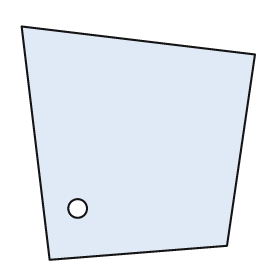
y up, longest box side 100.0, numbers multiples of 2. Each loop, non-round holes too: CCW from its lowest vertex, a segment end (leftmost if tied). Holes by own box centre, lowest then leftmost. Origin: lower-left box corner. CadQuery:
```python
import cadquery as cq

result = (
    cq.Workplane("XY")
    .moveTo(12.0, 0.0)
    .lineTo(88.0, 6.0)
    .lineTo(100.0, 88.0)
    .lineTo(0.0, 100.0)
    .close()
    .moveTo(24.0, 22.0)
    .circle(4.0)
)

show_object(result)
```